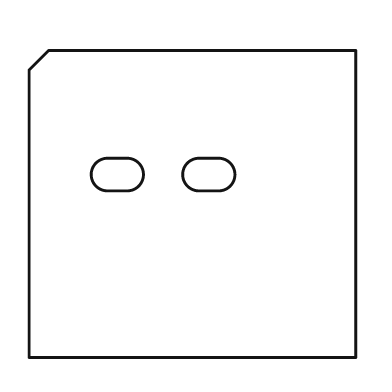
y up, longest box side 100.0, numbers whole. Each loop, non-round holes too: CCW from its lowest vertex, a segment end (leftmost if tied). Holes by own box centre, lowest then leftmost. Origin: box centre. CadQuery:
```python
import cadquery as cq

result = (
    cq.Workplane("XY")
    .moveTo(-50.0, -47.0)
    .lineTo(50.0, -47.0)
    .lineTo(50.0, 47.0)
    .lineTo(-44.0, 47.0)
    .lineTo(-50.0, 41.0)
    .close()
    .moveTo(-26.0, 4.0)
    .lineTo(-20.0, 4.0)
    .threePointArc((-15.0, 9.0), (-20.0, 14.0))
    .lineTo(-26.0, 14.0)
    .threePointArc((-31.0, 9.0), (-26.0, 4.0))
    .close()
    .moveTo(2.0, 4.0)
    .lineTo(8.0, 4.0)
    .threePointArc((13.0, 9.0), (8.0, 14.0))
    .lineTo(2.0, 14.0)
    .threePointArc((-3.0, 9.0), (2.0, 4.0))
    .close()
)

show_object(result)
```